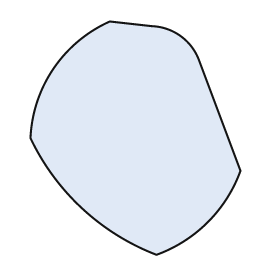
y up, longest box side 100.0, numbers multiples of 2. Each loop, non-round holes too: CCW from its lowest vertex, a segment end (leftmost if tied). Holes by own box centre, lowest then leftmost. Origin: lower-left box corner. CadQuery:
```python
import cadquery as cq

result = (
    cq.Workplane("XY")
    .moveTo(54.0, 0.0)
    .threePointArc((76.0, 14.0), (90.0, 36.0))
    .lineTo(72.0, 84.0)
    .threePointArc((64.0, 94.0), (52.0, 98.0))
    .lineTo(34.0, 100.0)
    .threePointArc((10.0, 80.0), (0.0, 50.0))
    .threePointArc((22.0, 20.0), (54.0, 0.0))
    .close()
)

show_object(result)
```